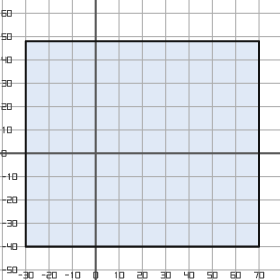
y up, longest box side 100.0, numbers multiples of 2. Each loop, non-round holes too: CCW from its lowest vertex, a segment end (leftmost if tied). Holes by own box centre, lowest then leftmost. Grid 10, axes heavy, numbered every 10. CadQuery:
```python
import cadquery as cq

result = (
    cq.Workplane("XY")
    .moveTo(-30.0, -40.0)
    .lineTo(70.0, -40.0)
    .lineTo(70.0, 48.0)
    .lineTo(-30.0, 48.0)
    .close()
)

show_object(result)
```